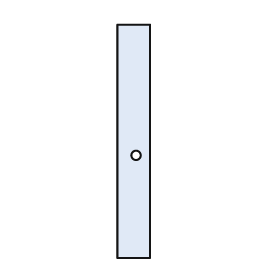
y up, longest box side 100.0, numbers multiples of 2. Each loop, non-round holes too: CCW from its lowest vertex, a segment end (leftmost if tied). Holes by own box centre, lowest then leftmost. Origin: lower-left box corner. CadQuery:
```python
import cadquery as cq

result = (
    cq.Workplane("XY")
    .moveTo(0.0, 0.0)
    .lineTo(14.0, 0.0)
    .lineTo(14.0, 100.0)
    .lineTo(0.0, 100.0)
    .close()
    .moveTo(8.0, 44.0)
    .circle(2.0)
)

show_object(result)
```